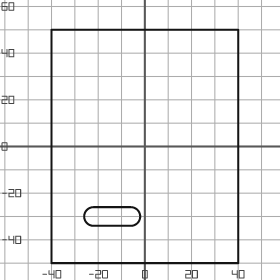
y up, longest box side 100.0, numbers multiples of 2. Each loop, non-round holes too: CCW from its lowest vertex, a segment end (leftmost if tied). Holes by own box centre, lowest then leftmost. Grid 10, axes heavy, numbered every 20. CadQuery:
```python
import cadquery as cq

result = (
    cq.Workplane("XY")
    .moveTo(-40.0, -50.0)
    .lineTo(40.0, -50.0)
    .lineTo(40.0, 50.0)
    .lineTo(-40.0, 50.0)
    .close()
    .moveTo(-22.0, -34.0)
    .lineTo(-6.0, -34.0)
    .threePointArc((-2.0, -30.0), (-6.0, -26.0))
    .lineTo(-22.0, -26.0)
    .threePointArc((-26.0, -30.0), (-22.0, -34.0))
    .close()
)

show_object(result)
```